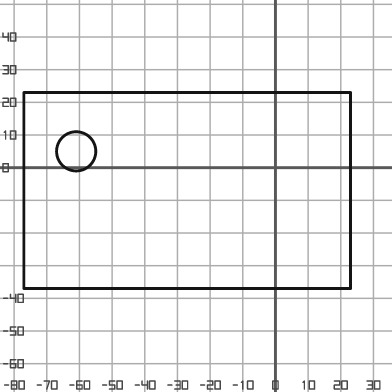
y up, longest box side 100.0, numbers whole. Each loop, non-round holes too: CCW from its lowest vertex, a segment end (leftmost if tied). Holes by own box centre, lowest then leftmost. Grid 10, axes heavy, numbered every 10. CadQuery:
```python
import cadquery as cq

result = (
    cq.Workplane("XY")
    .moveTo(-77.0, -37.0)
    .lineTo(23.0, -37.0)
    .lineTo(23.0, 23.0)
    .lineTo(-77.0, 23.0)
    .close()
    .moveTo(-61.0, 5.0)
    .circle(6.0)
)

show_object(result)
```